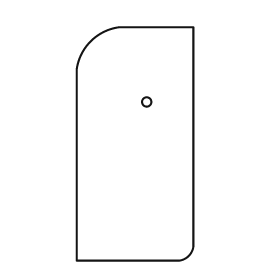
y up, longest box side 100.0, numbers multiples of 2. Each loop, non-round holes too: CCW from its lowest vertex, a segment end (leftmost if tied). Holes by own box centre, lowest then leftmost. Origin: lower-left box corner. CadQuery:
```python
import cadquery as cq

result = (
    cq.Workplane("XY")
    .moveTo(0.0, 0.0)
    .lineTo(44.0, 0.0)
    .threePointArc((48.0, 2.0), (50.0, 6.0))
    .lineTo(50.0, 100.0)
    .lineTo(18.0, 100.0)
    .threePointArc((6.0, 94.0), (0.0, 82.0))
    .close()
    .moveTo(30.0, 68.0)
    .circle(2.0)
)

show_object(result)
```